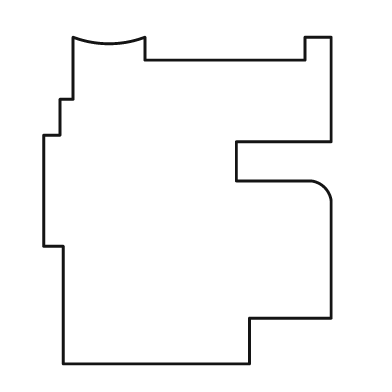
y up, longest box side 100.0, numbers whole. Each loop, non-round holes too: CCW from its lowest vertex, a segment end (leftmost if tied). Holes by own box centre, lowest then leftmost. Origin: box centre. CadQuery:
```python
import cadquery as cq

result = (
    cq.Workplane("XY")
    .moveTo(-38.0, -50.0)
    .lineTo(19.0, -50.0)
    .lineTo(19.0, -36.0)
    .lineTo(44.0, -36.0)
    .lineTo(44.0, 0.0)
    .threePointArc((42.0, 4.0), (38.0, 6.0))
    .lineTo(15.0, 6.0)
    .lineTo(15.0, 18.0)
    .lineTo(44.0, 18.0)
    .lineTo(44.0, 50.0)
    .lineTo(36.0, 50.0)
    .lineTo(36.0, 43.0)
    .lineTo(-13.0, 43.0)
    .lineTo(-13.0, 50.0)
    .threePointArc((-24.0, 48.0), (-35.0, 50.0))
    .lineTo(-35.0, 31.0)
    .lineTo(-39.0, 31.0)
    .lineTo(-39.0, 20.0)
    .lineTo(-44.0, 20.0)
    .lineTo(-44.0, -14.0)
    .lineTo(-38.0, -14.0)
    .close()
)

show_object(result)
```